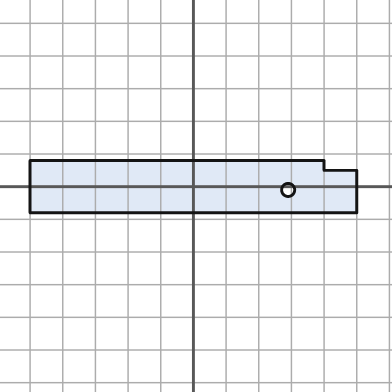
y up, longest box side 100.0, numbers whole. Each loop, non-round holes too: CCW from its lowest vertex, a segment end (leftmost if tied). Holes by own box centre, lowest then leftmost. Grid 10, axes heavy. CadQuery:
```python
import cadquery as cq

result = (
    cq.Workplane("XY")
    .moveTo(-50.0, -8.0)
    .lineTo(50.0, -8.0)
    .lineTo(50.0, 5.0)
    .lineTo(40.0, 5.0)
    .lineTo(40.0, 8.0)
    .lineTo(-50.0, 8.0)
    .close()
    .moveTo(29.0, -1.0)
    .circle(2.0)
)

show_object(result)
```